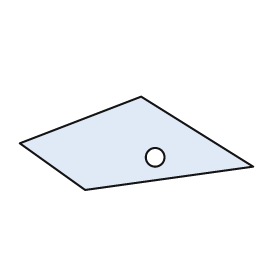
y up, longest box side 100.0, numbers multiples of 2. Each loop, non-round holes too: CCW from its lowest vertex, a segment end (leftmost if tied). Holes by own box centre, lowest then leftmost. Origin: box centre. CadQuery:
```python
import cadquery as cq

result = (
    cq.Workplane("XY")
    .moveTo(-22.0, -20.0)
    .lineTo(50.0, -10.0)
    .lineTo(2.0, 20.0)
    .lineTo(-50.0, 0.0)
    .close()
    .moveTo(8.0, -6.0)
    .circle(4.0)
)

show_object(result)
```